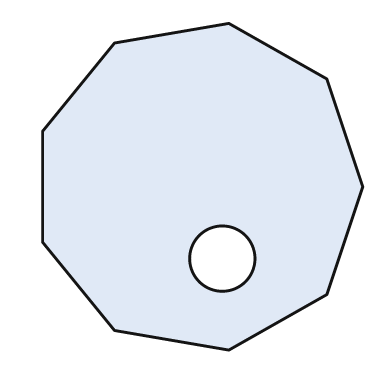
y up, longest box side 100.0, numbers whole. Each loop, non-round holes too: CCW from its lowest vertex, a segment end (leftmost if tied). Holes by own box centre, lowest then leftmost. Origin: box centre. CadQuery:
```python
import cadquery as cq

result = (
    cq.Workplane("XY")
    .moveTo(8.0, -50.0)
    .lineTo(38.0, -33.0)
    .lineTo(49.0, 0.0)
    .lineTo(38.0, 33.0)
    .lineTo(8.0, 50.0)
    .lineTo(-27.0, 44.0)
    .lineTo(-49.0, 17.0)
    .lineTo(-49.0, -17.0)
    .lineTo(-27.0, -44.0)
    .close()
    .moveTo(6.0, -22.0)
    .circle(10.0)
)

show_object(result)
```